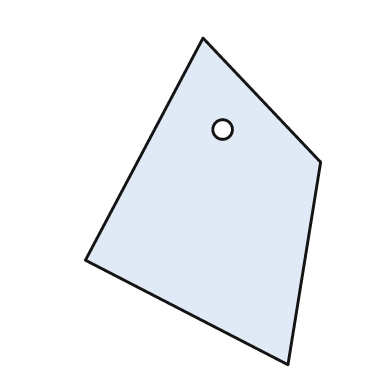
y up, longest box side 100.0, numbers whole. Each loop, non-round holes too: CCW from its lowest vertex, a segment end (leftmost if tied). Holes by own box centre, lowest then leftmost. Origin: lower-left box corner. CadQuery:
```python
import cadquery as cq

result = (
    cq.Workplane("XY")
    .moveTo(62.0, 0.0)
    .lineTo(72.0, 62.0)
    .lineTo(36.0, 100.0)
    .lineTo(0.0, 32.0)
    .close()
    .moveTo(42.0, 72.0)
    .circle(3.0)
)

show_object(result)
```